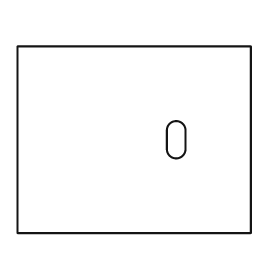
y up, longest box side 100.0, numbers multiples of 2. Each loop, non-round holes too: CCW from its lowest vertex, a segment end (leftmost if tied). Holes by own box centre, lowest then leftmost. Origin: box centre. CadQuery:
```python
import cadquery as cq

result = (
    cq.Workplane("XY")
    .moveTo(-50.0, -40.0)
    .lineTo(50.0, -40.0)
    .lineTo(50.0, 40.0)
    .lineTo(-50.0, 40.0)
    .close()
    .moveTo(14.0, -4.0)
    .threePointArc((18.0, -8.0), (22.0, -4.0))
    .lineTo(22.0, 4.0)
    .threePointArc((18.0, 8.0), (14.0, 4.0))
    .close()
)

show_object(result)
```